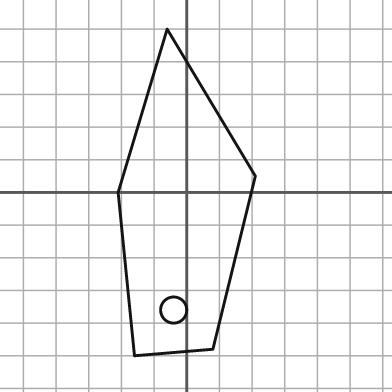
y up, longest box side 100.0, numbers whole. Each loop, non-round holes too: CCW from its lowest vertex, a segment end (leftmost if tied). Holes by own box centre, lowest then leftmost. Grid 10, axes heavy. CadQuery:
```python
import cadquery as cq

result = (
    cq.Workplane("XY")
    .moveTo(-16.0, -50.0)
    .lineTo(8.0, -48.0)
    .lineTo(21.0, 5.0)
    .lineTo(-6.0, 50.0)
    .lineTo(-21.0, 0.0)
    .close()
    .moveTo(-4.0, -36.0)
    .circle(4.0)
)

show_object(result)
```